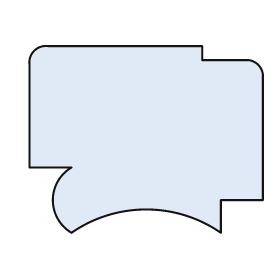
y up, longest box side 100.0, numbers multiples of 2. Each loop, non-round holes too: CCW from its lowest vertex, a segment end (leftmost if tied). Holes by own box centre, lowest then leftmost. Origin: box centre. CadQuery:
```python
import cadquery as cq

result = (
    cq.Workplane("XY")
    .moveTo(-32.0, -40.0)
    .threePointArc((0.0, -30.0), (32.0, -40.0))
    .lineTo(32.0, -26.0)
    .lineTo(50.0, -26.0)
    .lineTo(50.0, 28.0)
    .threePointArc((48.0, 32.0), (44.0, 34.0))
    .lineTo(24.0, 34.0)
    .lineTo(24.0, 40.0)
    .lineTo(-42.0, 40.0)
    .threePointArc((-48.0, 38.0), (-50.0, 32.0))
    .lineTo(-50.0, -12.0)
    .lineTo(-32.0, -12.0)
    .threePointArc((-40.0, -26.0), (-32.0, -40.0))
    .close()
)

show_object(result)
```